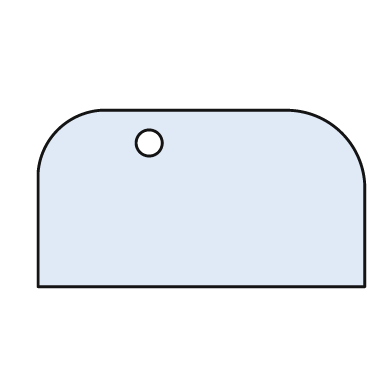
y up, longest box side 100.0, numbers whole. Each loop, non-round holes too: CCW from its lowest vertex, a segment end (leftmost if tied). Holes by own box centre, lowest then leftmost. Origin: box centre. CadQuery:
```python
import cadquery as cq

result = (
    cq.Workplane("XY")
    .moveTo(-50.0, -27.0)
    .lineTo(50.0, -27.0)
    .lineTo(50.0, 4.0)
    .threePointArc((43.0, 20.0), (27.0, 27.0))
    .lineTo(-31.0, 27.0)
    .threePointArc((-44.0, 21.0), (-50.0, 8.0))
    .close()
    .moveTo(-16.0, 17.0)
    .circle(4.0)
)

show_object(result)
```